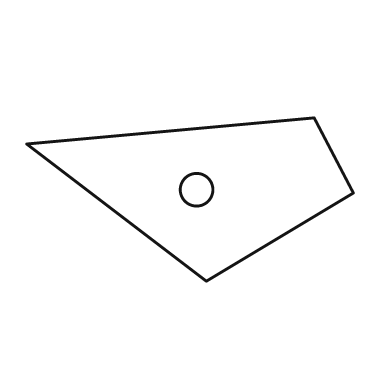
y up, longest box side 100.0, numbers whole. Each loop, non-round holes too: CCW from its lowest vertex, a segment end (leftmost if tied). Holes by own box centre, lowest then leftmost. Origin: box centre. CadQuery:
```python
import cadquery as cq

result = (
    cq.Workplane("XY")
    .moveTo(5.0, -25.0)
    .lineTo(50.0, 2.0)
    .lineTo(38.0, 25.0)
    .lineTo(-50.0, 17.0)
    .close()
    .moveTo(2.0, 3.0)
    .circle(5.0)
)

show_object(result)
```